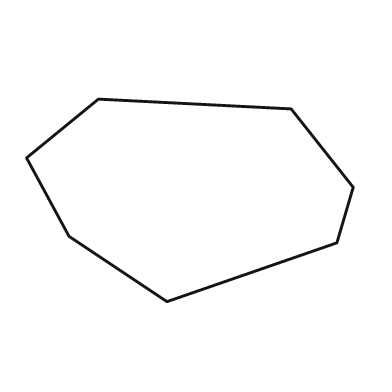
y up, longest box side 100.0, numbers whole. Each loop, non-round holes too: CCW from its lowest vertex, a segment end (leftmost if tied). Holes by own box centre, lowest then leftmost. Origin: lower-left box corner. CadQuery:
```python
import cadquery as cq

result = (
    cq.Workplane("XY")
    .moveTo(43.0, 0.0)
    .lineTo(95.0, 18.0)
    .lineTo(100.0, 35.0)
    .lineTo(81.0, 59.0)
    .lineTo(22.0, 62.0)
    .lineTo(0.0, 44.0)
    .lineTo(13.0, 20.0)
    .close()
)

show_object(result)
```